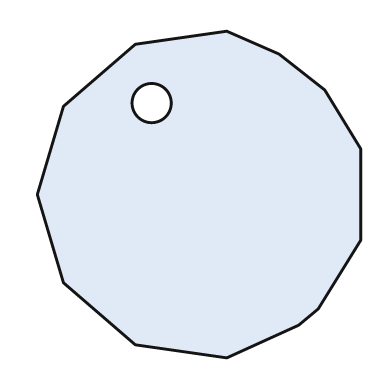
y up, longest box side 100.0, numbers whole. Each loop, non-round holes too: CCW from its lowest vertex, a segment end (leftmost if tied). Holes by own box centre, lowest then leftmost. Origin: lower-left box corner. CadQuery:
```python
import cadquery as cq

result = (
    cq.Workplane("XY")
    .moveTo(58.0, 0.0)
    .lineTo(80.0, 10.0)
    .lineTo(86.0, 15.0)
    .lineTo(99.0, 36.0)
    .lineTo(99.0, 64.0)
    .lineTo(88.0, 82.0)
    .lineTo(74.0, 93.0)
    .lineTo(58.0, 100.0)
    .lineTo(30.0, 96.0)
    .lineTo(8.0, 77.0)
    .lineTo(0.0, 50.0)
    .lineTo(8.0, 23.0)
    .lineTo(30.0, 4.0)
    .close()
    .moveTo(35.0, 78.0)
    .circle(6.0)
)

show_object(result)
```